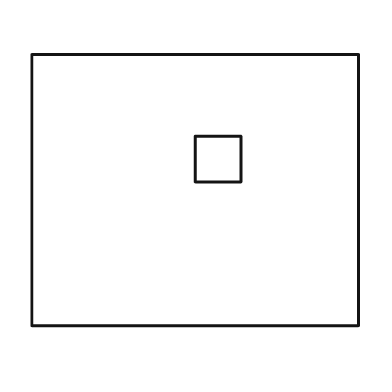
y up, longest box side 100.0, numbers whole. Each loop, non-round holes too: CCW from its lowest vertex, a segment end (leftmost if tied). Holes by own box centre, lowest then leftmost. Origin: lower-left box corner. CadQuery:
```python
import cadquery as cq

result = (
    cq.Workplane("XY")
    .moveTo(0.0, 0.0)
    .lineTo(100.0, 0.0)
    .lineTo(100.0, 83.0)
    .lineTo(0.0, 83.0)
    .close()
    .moveTo(50.0, 44.0)
    .lineTo(64.0, 44.0)
    .lineTo(64.0, 58.0)
    .lineTo(50.0, 58.0)
    .close()
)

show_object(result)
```